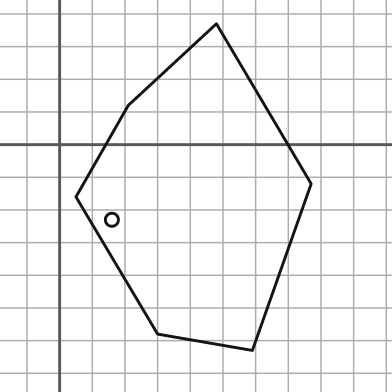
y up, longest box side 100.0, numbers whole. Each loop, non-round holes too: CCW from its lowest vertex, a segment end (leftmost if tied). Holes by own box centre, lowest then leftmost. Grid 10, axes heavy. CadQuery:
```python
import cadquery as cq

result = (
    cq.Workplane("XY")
    .moveTo(59.0, -63.0)
    .lineTo(77.0, -12.0)
    .lineTo(48.0, 37.0)
    .lineTo(21.0, 12.0)
    .lineTo(5.0, -16.0)
    .lineTo(30.0, -58.0)
    .close()
    .moveTo(16.0, -23.0)
    .circle(2.0)
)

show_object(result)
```